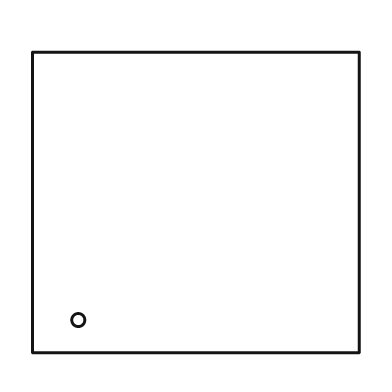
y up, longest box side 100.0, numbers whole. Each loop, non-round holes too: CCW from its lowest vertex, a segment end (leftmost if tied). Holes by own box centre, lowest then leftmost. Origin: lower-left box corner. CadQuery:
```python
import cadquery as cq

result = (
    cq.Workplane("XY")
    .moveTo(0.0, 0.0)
    .lineTo(100.0, 0.0)
    .lineTo(100.0, 92.0)
    .lineTo(0.0, 92.0)
    .close()
    .moveTo(14.0, 10.0)
    .circle(2.0)
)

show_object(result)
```